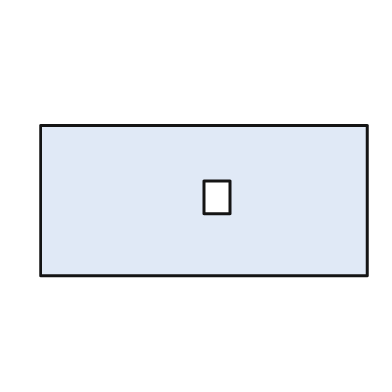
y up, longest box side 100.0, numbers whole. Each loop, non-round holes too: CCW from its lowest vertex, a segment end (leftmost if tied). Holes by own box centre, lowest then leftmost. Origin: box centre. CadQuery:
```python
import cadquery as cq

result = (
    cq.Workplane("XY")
    .moveTo(-50.0, -23.0)
    .lineTo(50.0, -23.0)
    .lineTo(50.0, 23.0)
    .lineTo(-50.0, 23.0)
    .close()
    .moveTo(0.0, -4.0)
    .lineTo(8.0, -4.0)
    .lineTo(8.0, 6.0)
    .lineTo(0.0, 6.0)
    .close()
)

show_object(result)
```